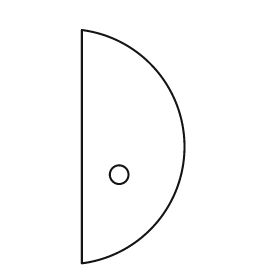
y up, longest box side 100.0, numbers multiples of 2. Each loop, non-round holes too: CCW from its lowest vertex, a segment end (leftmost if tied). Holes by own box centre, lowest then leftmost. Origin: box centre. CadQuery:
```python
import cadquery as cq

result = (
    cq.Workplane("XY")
    .moveTo(-22.0, -50.0)
    .threePointArc((22.0, 0.0), (-22.0, 50.0))
    .close()
    .moveTo(-6.0, -12.0)
    .circle(4.0)
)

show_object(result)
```